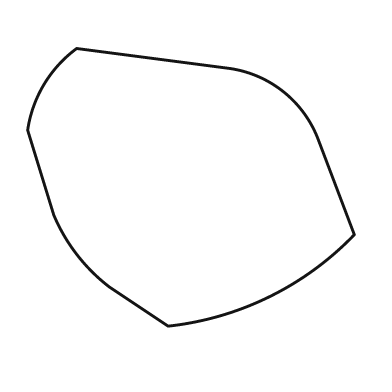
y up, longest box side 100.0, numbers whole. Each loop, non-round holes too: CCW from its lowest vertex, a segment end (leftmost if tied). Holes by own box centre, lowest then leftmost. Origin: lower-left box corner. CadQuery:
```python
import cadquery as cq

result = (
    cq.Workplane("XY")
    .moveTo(43.0, 0.0)
    .threePointArc((74.0, 9.0), (100.0, 28.0))
    .lineTo(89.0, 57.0)
    .threePointArc((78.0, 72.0), (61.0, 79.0))
    .lineTo(15.0, 85.0)
    .threePointArc((5.0, 74.0), (0.0, 60.0))
    .lineTo(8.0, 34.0)
    .threePointArc((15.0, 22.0), (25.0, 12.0))
    .close()
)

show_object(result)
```